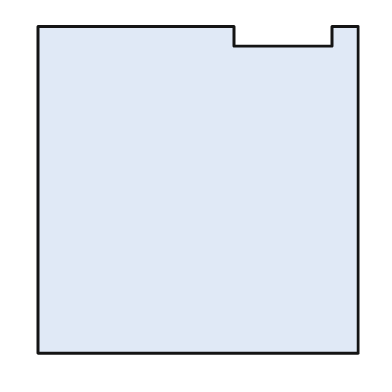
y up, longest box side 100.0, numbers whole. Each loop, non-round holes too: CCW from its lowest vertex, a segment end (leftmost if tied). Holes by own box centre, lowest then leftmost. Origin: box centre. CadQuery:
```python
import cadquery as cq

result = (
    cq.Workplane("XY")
    .moveTo(-49.0, -50.0)
    .lineTo(49.0, -50.0)
    .lineTo(49.0, 50.0)
    .lineTo(41.0, 50.0)
    .lineTo(41.0, 44.0)
    .lineTo(11.0, 44.0)
    .lineTo(11.0, 50.0)
    .lineTo(-49.0, 50.0)
    .close()
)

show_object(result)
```